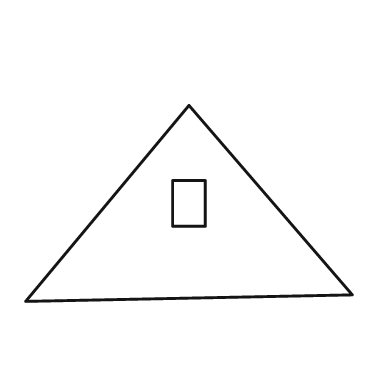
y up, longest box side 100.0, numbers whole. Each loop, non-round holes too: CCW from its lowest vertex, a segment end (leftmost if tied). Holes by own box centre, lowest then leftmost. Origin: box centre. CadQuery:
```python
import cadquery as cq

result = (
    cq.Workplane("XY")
    .moveTo(-50.0, -30.0)
    .lineTo(50.0, -28.0)
    .lineTo(0.0, 30.0)
    .close()
    .moveTo(-5.0, -7.0)
    .lineTo(5.0, -7.0)
    .lineTo(5.0, 7.0)
    .lineTo(-5.0, 7.0)
    .close()
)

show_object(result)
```